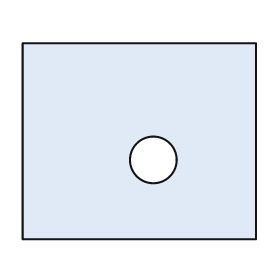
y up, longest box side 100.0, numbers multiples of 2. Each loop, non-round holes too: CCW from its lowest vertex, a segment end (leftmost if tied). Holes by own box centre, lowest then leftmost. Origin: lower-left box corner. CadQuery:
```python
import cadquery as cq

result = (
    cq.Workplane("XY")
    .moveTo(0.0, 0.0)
    .lineTo(100.0, 0.0)
    .lineTo(100.0, 84.0)
    .lineTo(0.0, 84.0)
    .close()
    .moveTo(56.0, 34.0)
    .circle(10.0)
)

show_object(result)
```